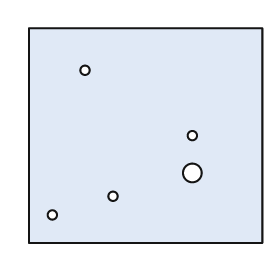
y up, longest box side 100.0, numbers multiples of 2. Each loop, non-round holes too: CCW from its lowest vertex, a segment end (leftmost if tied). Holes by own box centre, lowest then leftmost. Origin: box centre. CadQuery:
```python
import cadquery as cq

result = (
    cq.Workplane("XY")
    .moveTo(-50.0, -46.0)
    .lineTo(50.0, -46.0)
    .lineTo(50.0, 46.0)
    .lineTo(-50.0, 46.0)
    .close()
    .moveTo(-40.0, -34.0)
    .circle(2.0)
    .moveTo(-14.0, -26.0)
    .circle(2.0)
    .moveTo(20.0, -16.0)
    .circle(4.0)
    .moveTo(20.0, 0.0)
    .circle(2.0)
    .moveTo(-26.0, 28.0)
    .circle(2.0)
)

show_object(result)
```